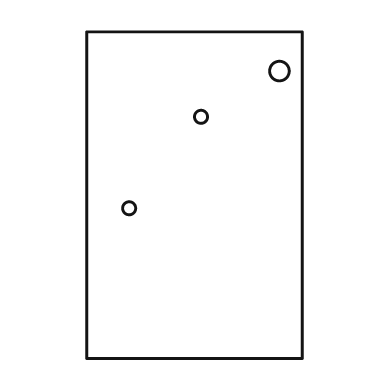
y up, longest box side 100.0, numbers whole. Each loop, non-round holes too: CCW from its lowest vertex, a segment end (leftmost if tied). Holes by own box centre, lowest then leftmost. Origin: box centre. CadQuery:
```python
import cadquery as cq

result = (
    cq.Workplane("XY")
    .moveTo(-33.0, -50.0)
    .lineTo(33.0, -50.0)
    .lineTo(33.0, 50.0)
    .lineTo(-33.0, 50.0)
    .close()
    .moveTo(-20.0, -4.0)
    .circle(2.0)
    .moveTo(2.0, 24.0)
    .circle(2.0)
    .moveTo(26.0, 38.0)
    .circle(3.0)
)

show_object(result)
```